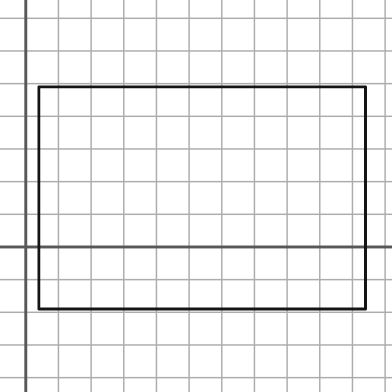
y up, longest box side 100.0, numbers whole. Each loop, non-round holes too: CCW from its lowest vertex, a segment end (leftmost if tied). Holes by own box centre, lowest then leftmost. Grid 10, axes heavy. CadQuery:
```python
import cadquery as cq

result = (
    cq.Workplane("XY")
    .moveTo(4.0, -19.0)
    .lineTo(104.0, -19.0)
    .lineTo(104.0, 49.0)
    .lineTo(4.0, 49.0)
    .close()
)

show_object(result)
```